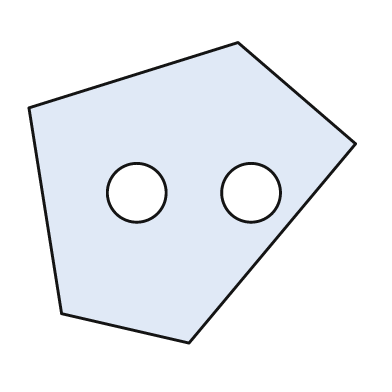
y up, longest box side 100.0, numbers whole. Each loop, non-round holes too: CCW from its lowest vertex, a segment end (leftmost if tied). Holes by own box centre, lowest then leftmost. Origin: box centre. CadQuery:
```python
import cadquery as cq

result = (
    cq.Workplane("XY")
    .moveTo(-1.0, -46.0)
    .lineTo(50.0, 15.0)
    .lineTo(14.0, 46.0)
    .lineTo(-50.0, 26.0)
    .lineTo(-40.0, -37.0)
    .close()
    .moveTo(-17.0, 0.0)
    .circle(9.0)
    .moveTo(18.0, 0.0)
    .circle(9.0)
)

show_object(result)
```